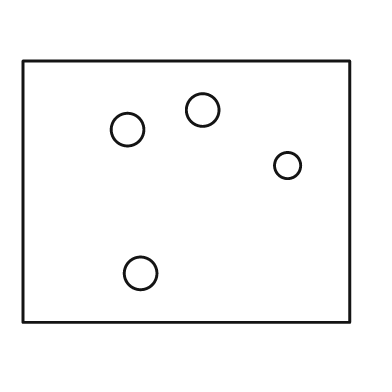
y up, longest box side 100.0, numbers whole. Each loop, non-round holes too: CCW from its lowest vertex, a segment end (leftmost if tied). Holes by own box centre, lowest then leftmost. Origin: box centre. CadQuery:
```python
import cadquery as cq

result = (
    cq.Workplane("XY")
    .moveTo(-50.0, -40.0)
    .lineTo(50.0, -40.0)
    .lineTo(50.0, 40.0)
    .lineTo(-50.0, 40.0)
    .close()
    .moveTo(-14.0, -25.0)
    .circle(5.0)
    .moveTo(31.0, 8.0)
    .circle(4.0)
    .moveTo(-18.0, 19.0)
    .circle(5.0)
    .moveTo(5.0, 25.0)
    .circle(5.0)
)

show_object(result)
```